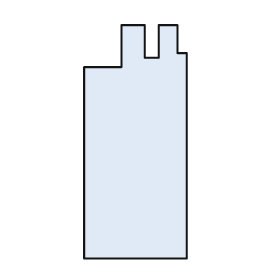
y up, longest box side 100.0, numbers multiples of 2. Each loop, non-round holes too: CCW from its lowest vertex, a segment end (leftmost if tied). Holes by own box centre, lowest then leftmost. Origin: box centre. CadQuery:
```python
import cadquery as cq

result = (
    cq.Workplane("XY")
    .moveTo(-22.0, -50.0)
    .lineTo(22.0, -50.0)
    .lineTo(22.0, 38.0)
    .lineTo(18.0, 38.0)
    .lineTo(18.0, 50.0)
    .lineTo(10.0, 50.0)
    .lineTo(10.0, 36.0)
    .lineTo(4.0, 36.0)
    .lineTo(4.0, 50.0)
    .lineTo(-6.0, 50.0)
    .lineTo(-6.0, 32.0)
    .lineTo(-22.0, 32.0)
    .close()
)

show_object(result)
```